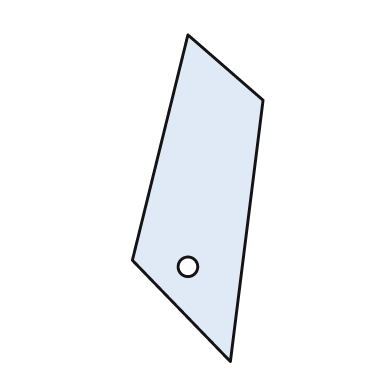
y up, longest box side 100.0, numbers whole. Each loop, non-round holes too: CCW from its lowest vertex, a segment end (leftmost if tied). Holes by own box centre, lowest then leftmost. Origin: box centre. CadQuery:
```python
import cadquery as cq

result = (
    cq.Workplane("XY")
    .moveTo(10.0, -50.0)
    .lineTo(20.0, 30.0)
    .lineTo(-3.0, 50.0)
    .lineTo(-20.0, -19.0)
    .close()
    .moveTo(-3.0, -21.0)
    .circle(3.0)
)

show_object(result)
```